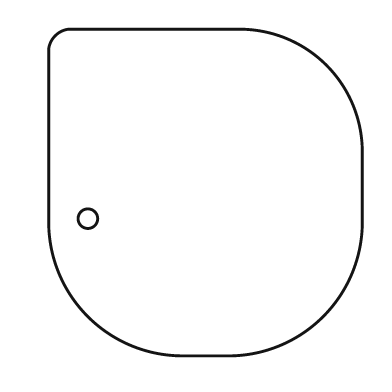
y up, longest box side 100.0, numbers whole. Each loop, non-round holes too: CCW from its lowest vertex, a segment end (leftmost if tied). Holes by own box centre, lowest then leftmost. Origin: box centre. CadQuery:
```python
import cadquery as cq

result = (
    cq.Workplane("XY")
    .moveTo(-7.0, -50.0)
    .lineTo(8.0, -50.0)
    .threePointArc((36.0, -38.0), (48.0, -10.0))
    .lineTo(48.0, 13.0)
    .threePointArc((37.0, 39.0), (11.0, 50.0))
    .lineTo(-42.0, 50.0)
    .threePointArc((-46.0, 48.0), (-48.0, 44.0))
    .lineTo(-48.0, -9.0)
    .threePointArc((-36.0, -38.0), (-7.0, -50.0))
    .close()
    .moveTo(-36.0, -8.0)
    .circle(3.0)
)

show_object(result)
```